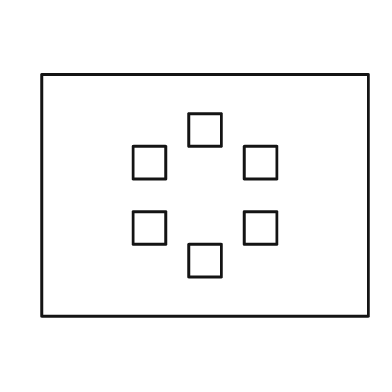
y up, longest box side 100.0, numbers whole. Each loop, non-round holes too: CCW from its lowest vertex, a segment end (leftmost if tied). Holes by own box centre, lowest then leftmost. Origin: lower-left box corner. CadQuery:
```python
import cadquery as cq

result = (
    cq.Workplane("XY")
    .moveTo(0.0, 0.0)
    .lineTo(100.0, 0.0)
    .lineTo(100.0, 74.0)
    .lineTo(0.0, 74.0)
    .close()
    .moveTo(45.0, 12.0)
    .lineTo(55.0, 12.0)
    .lineTo(55.0, 22.0)
    .lineTo(45.0, 22.0)
    .close()
    .moveTo(28.0, 22.0)
    .lineTo(38.0, 22.0)
    .lineTo(38.0, 32.0)
    .lineTo(28.0, 32.0)
    .close()
    .moveTo(62.0, 22.0)
    .lineTo(72.0, 22.0)
    .lineTo(72.0, 32.0)
    .lineTo(62.0, 32.0)
    .close()
    .moveTo(28.0, 42.0)
    .lineTo(38.0, 42.0)
    .lineTo(38.0, 52.0)
    .lineTo(28.0, 52.0)
    .close()
    .moveTo(62.0, 42.0)
    .lineTo(72.0, 42.0)
    .lineTo(72.0, 52.0)
    .lineTo(62.0, 52.0)
    .close()
    .moveTo(45.0, 52.0)
    .lineTo(55.0, 52.0)
    .lineTo(55.0, 62.0)
    .lineTo(45.0, 62.0)
    .close()
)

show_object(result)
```